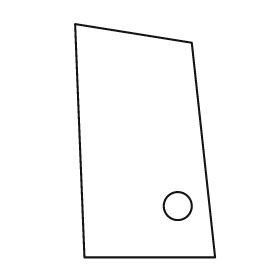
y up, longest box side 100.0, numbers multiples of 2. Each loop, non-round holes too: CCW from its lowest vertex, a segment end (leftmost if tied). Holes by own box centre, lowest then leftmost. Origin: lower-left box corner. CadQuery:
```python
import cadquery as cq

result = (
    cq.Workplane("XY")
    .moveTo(4.0, 0.0)
    .lineTo(60.0, 0.0)
    .lineTo(50.0, 92.0)
    .lineTo(0.0, 100.0)
    .close()
    .moveTo(44.0, 22.0)
    .circle(6.0)
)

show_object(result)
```